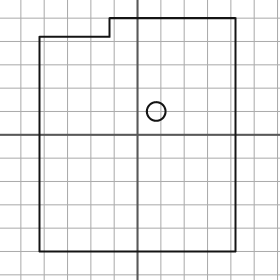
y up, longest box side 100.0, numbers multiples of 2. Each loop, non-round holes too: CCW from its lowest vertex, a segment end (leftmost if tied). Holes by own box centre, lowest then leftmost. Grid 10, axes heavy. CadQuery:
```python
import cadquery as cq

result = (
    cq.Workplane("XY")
    .moveTo(-42.0, -50.0)
    .lineTo(42.0, -50.0)
    .lineTo(42.0, 50.0)
    .lineTo(-12.0, 50.0)
    .lineTo(-12.0, 42.0)
    .lineTo(-42.0, 42.0)
    .close()
    .moveTo(8.0, 10.0)
    .circle(4.0)
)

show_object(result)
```